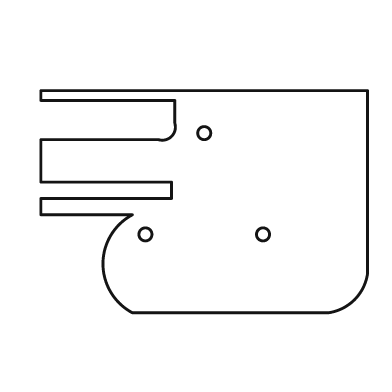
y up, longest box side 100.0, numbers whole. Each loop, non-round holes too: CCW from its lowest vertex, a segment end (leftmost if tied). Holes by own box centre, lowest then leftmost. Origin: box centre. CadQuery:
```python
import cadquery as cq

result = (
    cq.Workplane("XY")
    .moveTo(-22.0, -34.0)
    .lineTo(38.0, -34.0)
    .threePointArc((46.0, -30.0), (50.0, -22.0))
    .lineTo(50.0, 34.0)
    .lineTo(-50.0, 34.0)
    .lineTo(-50.0, 31.0)
    .lineTo(-9.0, 31.0)
    .lineTo(-9.0, 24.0)
    .threePointArc((-10.0, 20.0), (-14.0, 19.0))
    .lineTo(-50.0, 19.0)
    .lineTo(-50.0, 6.0)
    .lineTo(-10.0, 6.0)
    .lineTo(-10.0, 1.0)
    .lineTo(-50.0, 1.0)
    .lineTo(-50.0, -4.0)
    .lineTo(-22.0, -4.0)
    .threePointArc((-31.0, -19.0), (-22.0, -34.0))
    .close()
    .moveTo(-18.0, -10.0)
    .circle(2.0)
    .moveTo(18.0, -10.0)
    .circle(2.0)
    .moveTo(0.0, 21.0)
    .circle(2.0)
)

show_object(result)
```